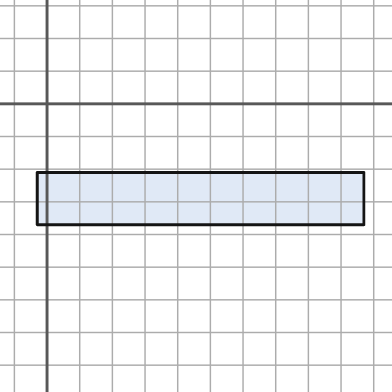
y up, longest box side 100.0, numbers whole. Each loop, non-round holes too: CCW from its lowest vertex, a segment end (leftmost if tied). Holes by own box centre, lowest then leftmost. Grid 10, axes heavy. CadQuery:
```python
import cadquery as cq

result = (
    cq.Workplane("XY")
    .moveTo(-3.0, -37.0)
    .lineTo(97.0, -37.0)
    .lineTo(97.0, -21.0)
    .lineTo(-3.0, -21.0)
    .close()
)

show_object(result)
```